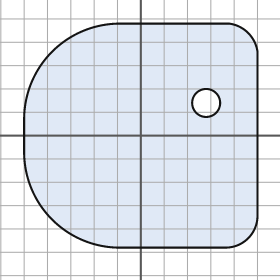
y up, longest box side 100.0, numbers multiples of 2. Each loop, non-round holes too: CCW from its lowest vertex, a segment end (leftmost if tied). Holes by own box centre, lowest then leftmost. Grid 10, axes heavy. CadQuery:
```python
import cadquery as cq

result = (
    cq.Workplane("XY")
    .moveTo(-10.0, -48.0)
    .lineTo(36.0, -48.0)
    .threePointArc((46.0, -44.0), (50.0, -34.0))
    .lineTo(50.0, 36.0)
    .threePointArc((46.0, 44.0), (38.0, 48.0))
    .lineTo(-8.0, 48.0)
    .threePointArc((-38.0, 36.0), (-50.0, 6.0))
    .lineTo(-50.0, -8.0)
    .threePointArc((-38.0, -36.0), (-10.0, -48.0))
    .close()
    .moveTo(28.0, 14.0)
    .circle(6.0)
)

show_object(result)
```